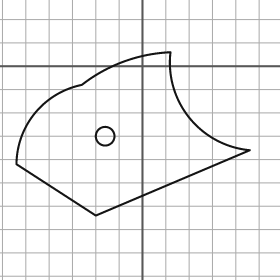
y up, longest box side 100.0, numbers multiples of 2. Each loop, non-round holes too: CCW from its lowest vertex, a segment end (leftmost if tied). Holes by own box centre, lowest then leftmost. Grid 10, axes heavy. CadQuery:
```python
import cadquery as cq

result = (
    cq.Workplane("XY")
    .moveTo(-20.0, -64.0)
    .lineTo(46.0, -36.0)
    .threePointArc((20.0, -22.0), (12.0, 6.0))
    .threePointArc((-8.0, 2.0), (-26.0, -8.0))
    .threePointArc((-46.0, -20.0), (-54.0, -42.0))
    .close()
    .moveTo(-16.0, -30.0)
    .circle(4.0)
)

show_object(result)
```